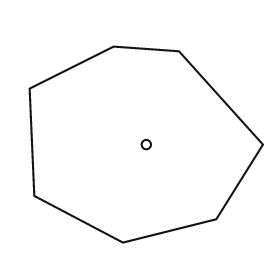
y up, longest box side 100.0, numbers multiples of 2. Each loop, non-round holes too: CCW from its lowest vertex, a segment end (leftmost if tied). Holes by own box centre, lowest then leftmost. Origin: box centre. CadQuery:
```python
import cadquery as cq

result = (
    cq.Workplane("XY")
    .moveTo(-10.0, -42.0)
    .lineTo(30.0, -32.0)
    .lineTo(50.0, 0.0)
    .lineTo(14.0, 40.0)
    .lineTo(-14.0, 42.0)
    .lineTo(-50.0, 24.0)
    .lineTo(-48.0, -22.0)
    .close()
    .moveTo(0.0, 0.0)
    .circle(2.0)
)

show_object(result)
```